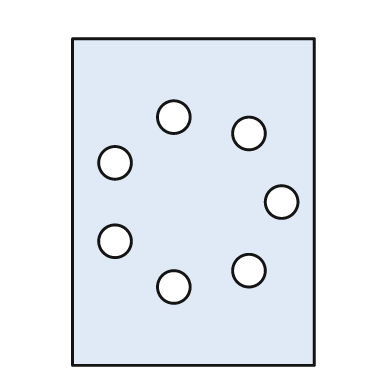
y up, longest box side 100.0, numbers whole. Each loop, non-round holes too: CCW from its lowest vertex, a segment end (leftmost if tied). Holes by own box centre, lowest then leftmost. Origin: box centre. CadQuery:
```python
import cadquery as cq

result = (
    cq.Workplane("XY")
    .moveTo(-37.0, -50.0)
    .lineTo(37.0, -50.0)
    .lineTo(37.0, 50.0)
    .lineTo(-37.0, 50.0)
    .close()
    .moveTo(-6.0, -26.0)
    .circle(5.0)
    .moveTo(17.0, -21.0)
    .circle(5.0)
    .moveTo(-24.0, -12.0)
    .circle(5.0)
    .moveTo(27.0, 0.0)
    .circle(5.0)
    .moveTo(-24.0, 12.0)
    .circle(5.0)
    .moveTo(17.0, 21.0)
    .circle(5.0)
    .moveTo(-6.0, 26.0)
    .circle(5.0)
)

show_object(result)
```